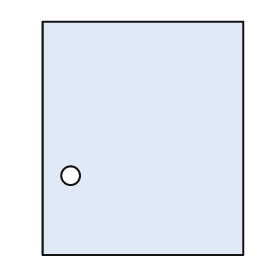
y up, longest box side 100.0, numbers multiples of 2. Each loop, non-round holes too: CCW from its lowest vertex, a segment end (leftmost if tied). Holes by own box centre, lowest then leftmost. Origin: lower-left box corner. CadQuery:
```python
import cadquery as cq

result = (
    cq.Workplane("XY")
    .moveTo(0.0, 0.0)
    .lineTo(86.0, 0.0)
    .lineTo(86.0, 100.0)
    .lineTo(0.0, 100.0)
    .close()
    .moveTo(12.0, 34.0)
    .circle(4.0)
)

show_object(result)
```